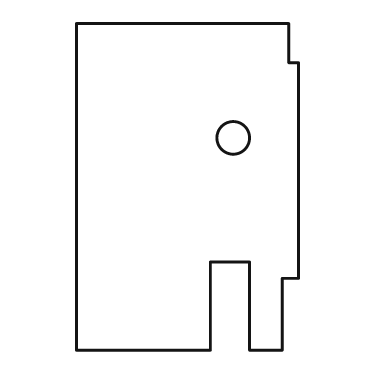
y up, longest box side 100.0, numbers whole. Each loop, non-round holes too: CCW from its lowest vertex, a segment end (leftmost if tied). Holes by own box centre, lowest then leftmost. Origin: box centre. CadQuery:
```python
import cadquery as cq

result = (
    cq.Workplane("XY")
    .moveTo(-34.0, -50.0)
    .lineTo(7.0, -50.0)
    .lineTo(7.0, -23.0)
    .lineTo(19.0, -23.0)
    .lineTo(19.0, -50.0)
    .lineTo(29.0, -50.0)
    .lineTo(29.0, -28.0)
    .lineTo(34.0, -28.0)
    .lineTo(34.0, 38.0)
    .lineTo(31.0, 38.0)
    .lineTo(31.0, 50.0)
    .lineTo(-34.0, 50.0)
    .close()
    .moveTo(14.0, 15.0)
    .circle(5.0)
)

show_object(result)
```